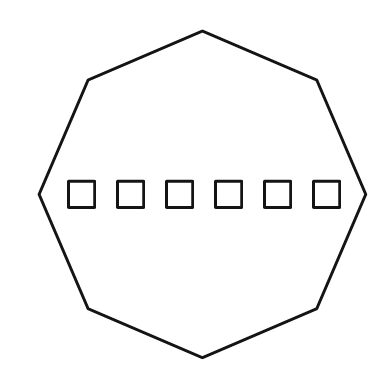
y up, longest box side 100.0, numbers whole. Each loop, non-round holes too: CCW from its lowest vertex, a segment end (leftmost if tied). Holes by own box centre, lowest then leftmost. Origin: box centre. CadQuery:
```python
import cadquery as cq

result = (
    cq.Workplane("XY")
    .moveTo(0.0, -50.0)
    .lineTo(35.0, -35.0)
    .lineTo(50.0, 0.0)
    .lineTo(35.0, 35.0)
    .lineTo(0.0, 50.0)
    .lineTo(-35.0, 35.0)
    .lineTo(-50.0, 0.0)
    .lineTo(-35.0, -35.0)
    .close()
    .moveTo(-41.0, -4.0)
    .lineTo(-33.0, -4.0)
    .lineTo(-33.0, 4.0)
    .lineTo(-41.0, 4.0)
    .close()
    .moveTo(-26.0, -4.0)
    .lineTo(-18.0, -4.0)
    .lineTo(-18.0, 4.0)
    .lineTo(-26.0, 4.0)
    .close()
    .moveTo(-11.0, -4.0)
    .lineTo(-3.0, -4.0)
    .lineTo(-3.0, 4.0)
    .lineTo(-11.0, 4.0)
    .close()
    .moveTo(4.0, -4.0)
    .lineTo(12.0, -4.0)
    .lineTo(12.0, 4.0)
    .lineTo(4.0, 4.0)
    .close()
    .moveTo(19.0, -4.0)
    .lineTo(27.0, -4.0)
    .lineTo(27.0, 4.0)
    .lineTo(19.0, 4.0)
    .close()
    .moveTo(34.0, -4.0)
    .lineTo(42.0, -4.0)
    .lineTo(42.0, 4.0)
    .lineTo(34.0, 4.0)
    .close()
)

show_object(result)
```